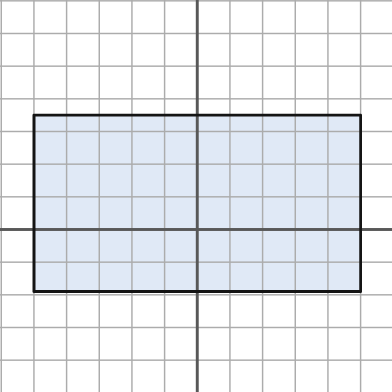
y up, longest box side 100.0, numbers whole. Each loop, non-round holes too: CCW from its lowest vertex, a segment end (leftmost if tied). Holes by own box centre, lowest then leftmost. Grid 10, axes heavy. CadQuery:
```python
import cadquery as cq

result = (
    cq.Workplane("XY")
    .moveTo(-50.0, -19.0)
    .lineTo(50.0, -19.0)
    .lineTo(50.0, 35.0)
    .lineTo(-50.0, 35.0)
    .close()
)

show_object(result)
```